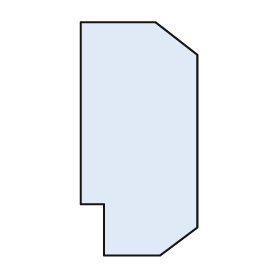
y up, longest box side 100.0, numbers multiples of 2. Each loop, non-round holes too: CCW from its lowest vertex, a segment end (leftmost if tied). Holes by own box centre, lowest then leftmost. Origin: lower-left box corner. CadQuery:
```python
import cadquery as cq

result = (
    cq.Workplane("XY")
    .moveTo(10.0, 0.0)
    .lineTo(34.0, 0.0)
    .lineTo(50.0, 12.0)
    .lineTo(50.0, 86.0)
    .lineTo(32.0, 100.0)
    .lineTo(0.0, 100.0)
    .lineTo(0.0, 22.0)
    .lineTo(10.0, 22.0)
    .close()
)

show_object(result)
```